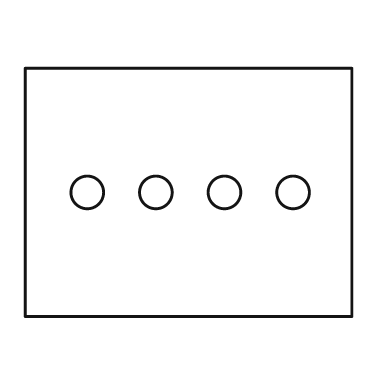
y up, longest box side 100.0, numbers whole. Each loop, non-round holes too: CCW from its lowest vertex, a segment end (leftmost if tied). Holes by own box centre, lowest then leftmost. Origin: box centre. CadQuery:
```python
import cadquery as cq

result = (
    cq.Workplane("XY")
    .moveTo(-50.0, -38.0)
    .lineTo(50.0, -38.0)
    .lineTo(50.0, 38.0)
    .lineTo(-50.0, 38.0)
    .close()
    .moveTo(-31.0, 0.0)
    .circle(5.0)
    .moveTo(-10.0, 0.0)
    .circle(5.0)
    .moveTo(11.0, 0.0)
    .circle(5.0)
    .moveTo(32.0, 0.0)
    .circle(5.0)
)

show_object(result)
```